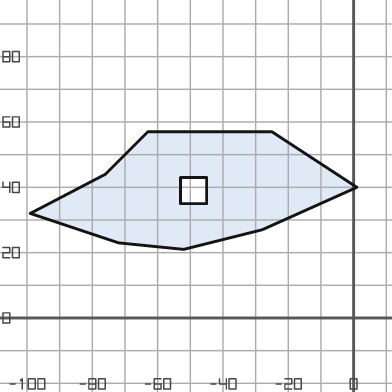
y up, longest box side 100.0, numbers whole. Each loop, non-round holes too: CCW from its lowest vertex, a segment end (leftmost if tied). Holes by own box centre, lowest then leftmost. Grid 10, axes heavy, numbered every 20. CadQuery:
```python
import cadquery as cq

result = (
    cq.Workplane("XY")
    .moveTo(-52.0, 21.0)
    .lineTo(-28.0, 27.0)
    .lineTo(1.0, 40.0)
    .lineTo(-25.0, 57.0)
    .lineTo(-63.0, 57.0)
    .lineTo(-76.0, 44.0)
    .lineTo(-99.0, 32.0)
    .lineTo(-72.0, 23.0)
    .close()
    .moveTo(-53.0, 35.0)
    .lineTo(-45.0, 35.0)
    .lineTo(-45.0, 43.0)
    .lineTo(-53.0, 43.0)
    .close()
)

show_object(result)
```